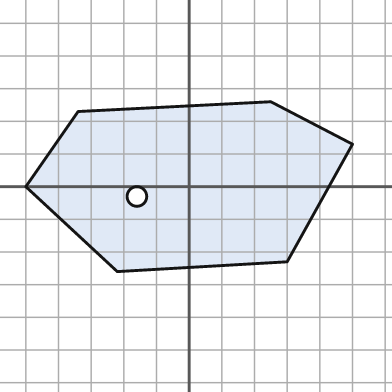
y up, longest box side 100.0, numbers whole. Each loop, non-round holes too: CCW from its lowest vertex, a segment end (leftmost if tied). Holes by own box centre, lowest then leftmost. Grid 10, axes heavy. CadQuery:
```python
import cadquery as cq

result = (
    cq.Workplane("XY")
    .moveTo(-22.0, -26.0)
    .lineTo(30.0, -23.0)
    .lineTo(50.0, 13.0)
    .lineTo(25.0, 26.0)
    .lineTo(-34.0, 23.0)
    .lineTo(-50.0, 0.0)
    .close()
    .moveTo(-16.0, -3.0)
    .circle(3.0)
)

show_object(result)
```